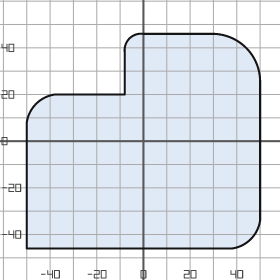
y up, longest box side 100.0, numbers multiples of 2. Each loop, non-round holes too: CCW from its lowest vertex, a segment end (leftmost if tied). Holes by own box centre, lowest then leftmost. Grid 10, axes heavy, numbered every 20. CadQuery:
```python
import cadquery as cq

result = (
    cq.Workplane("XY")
    .moveTo(-50.0, -46.0)
    .lineTo(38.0, -46.0)
    .threePointArc((46.0, -42.0), (50.0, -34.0))
    .lineTo(50.0, 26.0)
    .threePointArc((44.0, 40.0), (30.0, 46.0))
    .lineTo(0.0, 46.0)
    .threePointArc((-6.0, 44.0), (-8.0, 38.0))
    .lineTo(-8.0, 20.0)
    .lineTo(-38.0, 20.0)
    .threePointArc((-46.0, 16.0), (-50.0, 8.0))
    .close()
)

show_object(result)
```